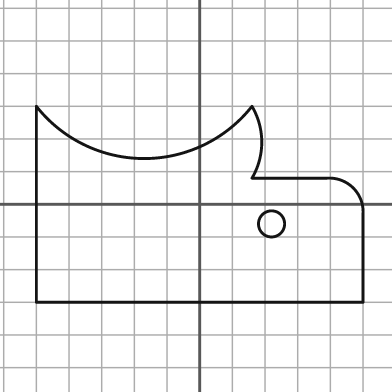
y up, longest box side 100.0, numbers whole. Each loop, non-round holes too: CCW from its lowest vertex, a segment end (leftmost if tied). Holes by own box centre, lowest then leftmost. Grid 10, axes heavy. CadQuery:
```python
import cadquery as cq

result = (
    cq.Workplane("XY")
    .moveTo(-50.0, -30.0)
    .lineTo(50.0, -30.0)
    .lineTo(50.0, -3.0)
    .threePointArc((47.0, 5.0), (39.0, 8.0))
    .lineTo(16.0, 8.0)
    .threePointArc((19.0, 19.0), (16.0, 30.0))
    .threePointArc((-17.0, 14.0), (-50.0, 30.0))
    .close()
    .moveTo(22.0, -6.0)
    .circle(4.0)
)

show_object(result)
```